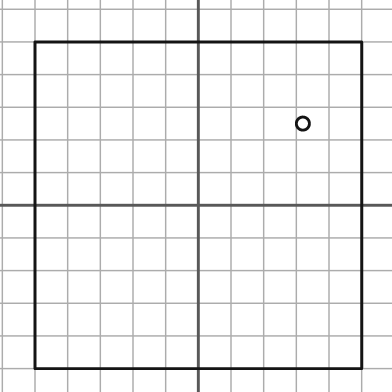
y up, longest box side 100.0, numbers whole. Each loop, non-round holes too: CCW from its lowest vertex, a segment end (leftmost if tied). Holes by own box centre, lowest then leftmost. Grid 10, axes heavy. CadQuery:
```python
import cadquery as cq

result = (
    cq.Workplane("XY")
    .moveTo(-50.0, -50.0)
    .lineTo(50.0, -50.0)
    .lineTo(50.0, 50.0)
    .lineTo(-50.0, 50.0)
    .close()
    .moveTo(32.0, 25.0)
    .circle(2.0)
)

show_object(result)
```